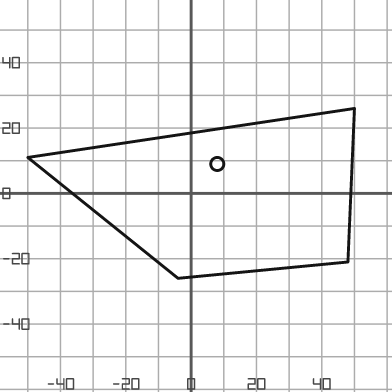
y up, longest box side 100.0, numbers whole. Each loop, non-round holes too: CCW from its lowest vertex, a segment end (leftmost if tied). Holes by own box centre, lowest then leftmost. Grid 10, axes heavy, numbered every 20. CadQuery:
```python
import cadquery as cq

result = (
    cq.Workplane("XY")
    .moveTo(-4.0, -26.0)
    .lineTo(48.0, -21.0)
    .lineTo(50.0, 26.0)
    .lineTo(-50.0, 11.0)
    .close()
    .moveTo(8.0, 9.0)
    .circle(2.0)
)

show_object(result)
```